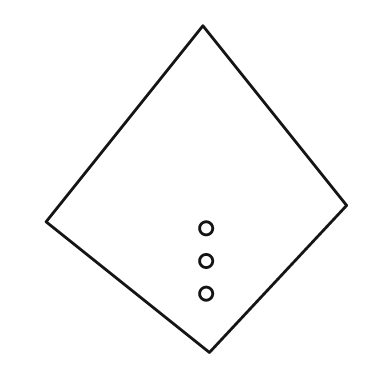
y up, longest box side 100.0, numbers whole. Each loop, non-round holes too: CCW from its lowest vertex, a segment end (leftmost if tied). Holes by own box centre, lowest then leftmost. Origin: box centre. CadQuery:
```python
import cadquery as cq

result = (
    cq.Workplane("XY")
    .moveTo(4.0, -50.0)
    .lineTo(46.0, -5.0)
    .lineTo(2.0, 50.0)
    .lineTo(-46.0, -10.0)
    .close()
    .moveTo(3.0, -32.0)
    .circle(2.0)
    .moveTo(3.0, -22.0)
    .circle(2.0)
    .moveTo(3.0, -12.0)
    .circle(2.0)
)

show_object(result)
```